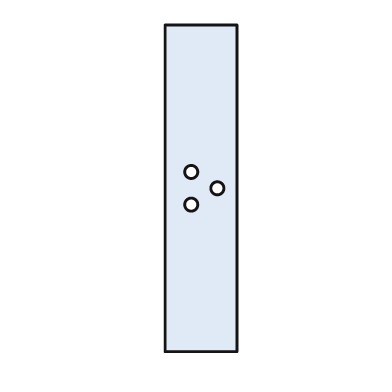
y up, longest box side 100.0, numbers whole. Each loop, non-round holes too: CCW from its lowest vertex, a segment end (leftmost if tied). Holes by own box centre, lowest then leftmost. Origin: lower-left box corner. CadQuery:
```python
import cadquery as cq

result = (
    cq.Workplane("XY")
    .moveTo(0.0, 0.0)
    .lineTo(22.0, 0.0)
    .lineTo(22.0, 100.0)
    .lineTo(0.0, 100.0)
    .close()
    .moveTo(8.0, 45.0)
    .circle(2.0)
    .moveTo(16.0, 50.0)
    .circle(2.0)
    .moveTo(8.0, 55.0)
    .circle(2.0)
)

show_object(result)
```